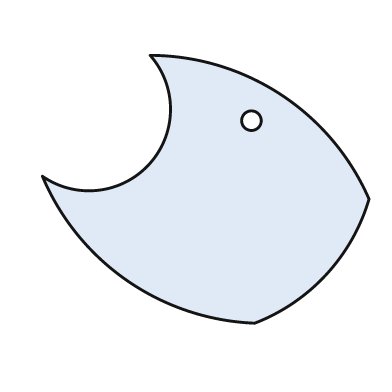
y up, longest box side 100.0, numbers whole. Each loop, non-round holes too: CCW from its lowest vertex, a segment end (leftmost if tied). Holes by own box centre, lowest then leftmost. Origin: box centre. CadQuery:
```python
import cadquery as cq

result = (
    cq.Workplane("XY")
    .moveTo(15.0, -41.0)
    .threePointArc((37.0, -26.0), (50.0, -3.0))
    .threePointArc((23.0, 29.0), (-17.0, 41.0))
    .threePointArc((-17.0, 8.0), (-50.0, 4.0))
    .threePointArc((-24.0, -28.0), (15.0, -41.0))
    .close()
    .moveTo(14.0, 21.0)
    .circle(3.0)
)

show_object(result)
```